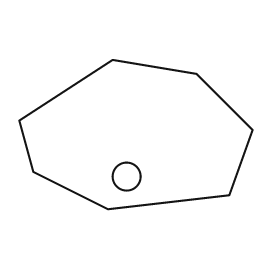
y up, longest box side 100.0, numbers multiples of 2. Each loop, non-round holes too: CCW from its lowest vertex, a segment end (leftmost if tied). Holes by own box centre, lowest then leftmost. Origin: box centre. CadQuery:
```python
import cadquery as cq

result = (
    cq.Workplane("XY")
    .moveTo(-12.0, -32.0)
    .lineTo(40.0, -26.0)
    .lineTo(50.0, 2.0)
    .lineTo(26.0, 26.0)
    .lineTo(-10.0, 32.0)
    .lineTo(-50.0, 6.0)
    .lineTo(-44.0, -16.0)
    .close()
    .moveTo(-4.0, -18.0)
    .circle(6.0)
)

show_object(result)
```